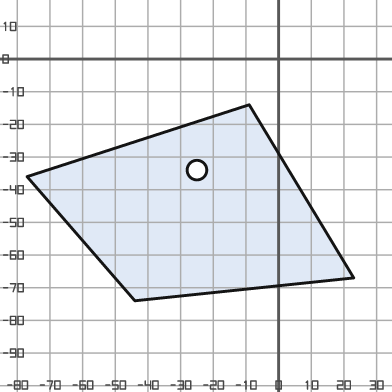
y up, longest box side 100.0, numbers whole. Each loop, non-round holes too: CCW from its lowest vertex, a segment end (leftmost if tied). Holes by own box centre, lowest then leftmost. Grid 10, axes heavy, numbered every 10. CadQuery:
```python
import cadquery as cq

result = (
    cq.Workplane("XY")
    .moveTo(-44.0, -74.0)
    .lineTo(23.0, -67.0)
    .lineTo(-9.0, -14.0)
    .lineTo(-77.0, -36.0)
    .close()
    .moveTo(-25.0, -34.0)
    .circle(3.0)
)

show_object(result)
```